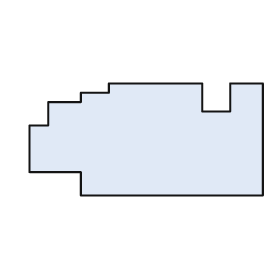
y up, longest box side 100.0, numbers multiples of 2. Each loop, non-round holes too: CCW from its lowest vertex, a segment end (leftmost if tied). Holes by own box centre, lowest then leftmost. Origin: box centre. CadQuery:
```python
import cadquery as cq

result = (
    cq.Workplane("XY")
    .moveTo(-28.0, -24.0)
    .lineTo(50.0, -24.0)
    .lineTo(50.0, 24.0)
    .lineTo(36.0, 24.0)
    .lineTo(36.0, 12.0)
    .lineTo(24.0, 12.0)
    .lineTo(24.0, 24.0)
    .lineTo(-16.0, 24.0)
    .lineTo(-16.0, 20.0)
    .lineTo(-28.0, 20.0)
    .lineTo(-28.0, 16.0)
    .lineTo(-42.0, 16.0)
    .lineTo(-42.0, 6.0)
    .lineTo(-50.0, 6.0)
    .lineTo(-50.0, -14.0)
    .lineTo(-28.0, -14.0)
    .close()
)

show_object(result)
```